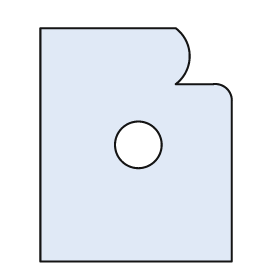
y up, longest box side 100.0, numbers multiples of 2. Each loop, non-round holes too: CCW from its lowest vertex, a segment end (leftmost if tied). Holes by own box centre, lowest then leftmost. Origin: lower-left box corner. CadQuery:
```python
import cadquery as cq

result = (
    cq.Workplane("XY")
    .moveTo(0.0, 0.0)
    .lineTo(82.0, 0.0)
    .lineTo(82.0, 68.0)
    .threePointArc((80.0, 74.0), (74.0, 76.0))
    .lineTo(58.0, 76.0)
    .threePointArc((64.0, 88.0), (58.0, 100.0))
    .lineTo(0.0, 100.0)
    .close()
    .moveTo(42.0, 50.0)
    .circle(10.0)
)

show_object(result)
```